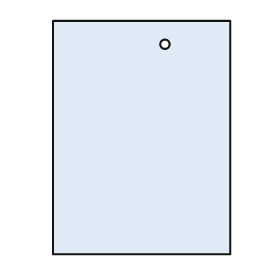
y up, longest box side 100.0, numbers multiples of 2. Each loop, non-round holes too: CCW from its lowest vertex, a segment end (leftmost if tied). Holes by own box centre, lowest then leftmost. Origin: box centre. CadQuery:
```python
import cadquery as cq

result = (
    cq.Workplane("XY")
    .moveTo(-38.0, -50.0)
    .lineTo(38.0, -50.0)
    .lineTo(38.0, 50.0)
    .lineTo(-38.0, 50.0)
    .close()
    .moveTo(10.0, 40.0)
    .circle(2.0)
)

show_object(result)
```